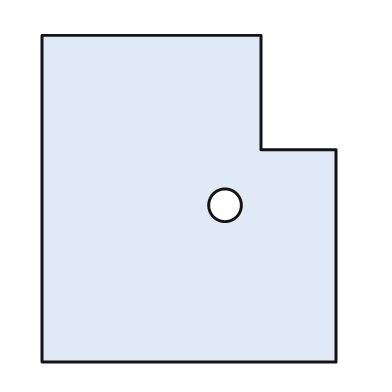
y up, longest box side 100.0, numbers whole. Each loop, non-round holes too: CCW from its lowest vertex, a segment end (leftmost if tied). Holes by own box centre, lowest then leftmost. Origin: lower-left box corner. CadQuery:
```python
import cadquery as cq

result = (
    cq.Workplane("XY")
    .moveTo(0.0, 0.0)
    .lineTo(90.0, 0.0)
    .lineTo(90.0, 65.0)
    .lineTo(67.0, 65.0)
    .lineTo(67.0, 100.0)
    .lineTo(0.0, 100.0)
    .close()
    .moveTo(56.0, 48.0)
    .circle(5.0)
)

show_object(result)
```